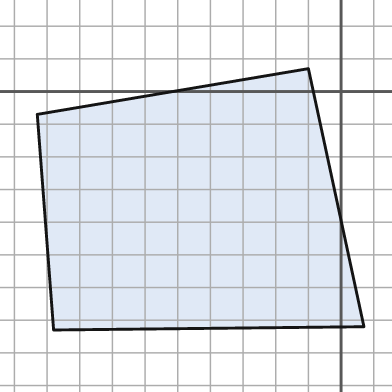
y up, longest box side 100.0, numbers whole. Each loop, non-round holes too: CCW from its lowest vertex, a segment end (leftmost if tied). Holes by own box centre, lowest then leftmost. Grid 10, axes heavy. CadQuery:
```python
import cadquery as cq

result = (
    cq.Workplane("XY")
    .moveTo(-88.0, -73.0)
    .lineTo(7.0, -72.0)
    .lineTo(-10.0, 7.0)
    .lineTo(-93.0, -7.0)
    .close()
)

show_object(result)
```